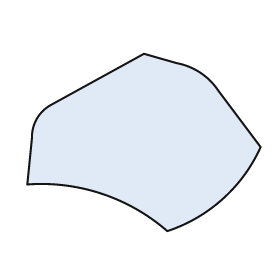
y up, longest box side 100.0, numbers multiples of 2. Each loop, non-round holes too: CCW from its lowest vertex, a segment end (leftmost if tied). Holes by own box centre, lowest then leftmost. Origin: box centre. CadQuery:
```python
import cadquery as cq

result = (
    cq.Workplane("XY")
    .moveTo(10.0, -38.0)
    .threePointArc((34.0, -24.0), (50.0, -2.0))
    .lineTo(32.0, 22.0)
    .threePointArc((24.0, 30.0), (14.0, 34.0))
    .lineTo(0.0, 38.0)
    .lineTo(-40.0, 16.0)
    .threePointArc((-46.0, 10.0), (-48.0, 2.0))
    .lineTo(-50.0, -18.0)
    .threePointArc((-18.0, -22.0), (10.0, -38.0))
    .close()
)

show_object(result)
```